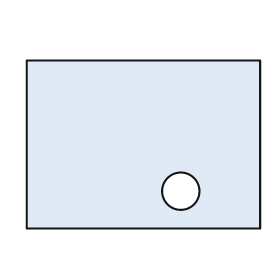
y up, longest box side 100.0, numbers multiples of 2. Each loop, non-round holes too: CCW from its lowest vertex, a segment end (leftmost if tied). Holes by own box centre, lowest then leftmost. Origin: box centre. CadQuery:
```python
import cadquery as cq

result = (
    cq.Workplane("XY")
    .moveTo(-50.0, -36.0)
    .lineTo(50.0, -36.0)
    .lineTo(50.0, 36.0)
    .lineTo(-50.0, 36.0)
    .close()
    .moveTo(16.0, -20.0)
    .circle(8.0)
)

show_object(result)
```